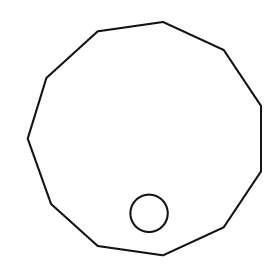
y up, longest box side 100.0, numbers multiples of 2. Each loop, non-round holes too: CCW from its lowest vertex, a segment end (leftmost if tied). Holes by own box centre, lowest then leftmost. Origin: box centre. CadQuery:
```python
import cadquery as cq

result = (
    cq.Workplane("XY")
    .moveTo(8.0, -50.0)
    .lineTo(34.0, -38.0)
    .lineTo(50.0, -14.0)
    .lineTo(50.0, 14.0)
    .lineTo(34.0, 38.0)
    .lineTo(8.0, 50.0)
    .lineTo(-20.0, 46.0)
    .lineTo(-42.0, 26.0)
    .lineTo(-50.0, 0.0)
    .lineTo(-40.0, -28.0)
    .lineTo(-20.0, -46.0)
    .close()
    .moveTo(2.0, -32.0)
    .circle(8.0)
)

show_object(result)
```